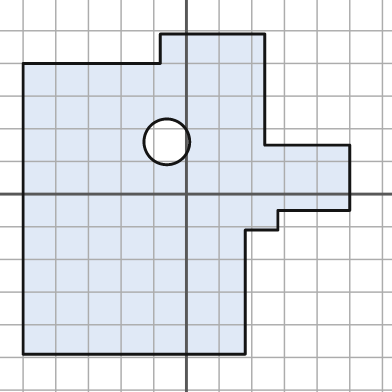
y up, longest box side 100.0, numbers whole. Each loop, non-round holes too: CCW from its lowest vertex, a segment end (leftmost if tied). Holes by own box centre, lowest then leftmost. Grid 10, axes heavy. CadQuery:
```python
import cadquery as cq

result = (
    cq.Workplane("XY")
    .moveTo(-50.0, -49.0)
    .lineTo(18.0, -49.0)
    .lineTo(18.0, -11.0)
    .lineTo(28.0, -11.0)
    .lineTo(28.0, -5.0)
    .lineTo(50.0, -5.0)
    .lineTo(50.0, 15.0)
    .lineTo(24.0, 15.0)
    .lineTo(24.0, 49.0)
    .lineTo(-8.0, 49.0)
    .lineTo(-8.0, 40.0)
    .lineTo(-50.0, 40.0)
    .close()
    .moveTo(-6.0, 16.0)
    .circle(7.0)
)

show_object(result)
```